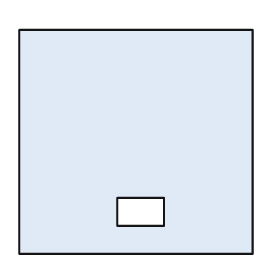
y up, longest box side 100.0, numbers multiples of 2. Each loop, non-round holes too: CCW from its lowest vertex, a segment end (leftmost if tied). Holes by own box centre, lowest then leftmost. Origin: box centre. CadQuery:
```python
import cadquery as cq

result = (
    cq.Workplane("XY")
    .moveTo(-50.0, -48.0)
    .lineTo(50.0, -48.0)
    .lineTo(50.0, 48.0)
    .lineTo(-50.0, 48.0)
    .close()
    .moveTo(-8.0, -36.0)
    .lineTo(12.0, -36.0)
    .lineTo(12.0, -24.0)
    .lineTo(-8.0, -24.0)
    .close()
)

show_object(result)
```